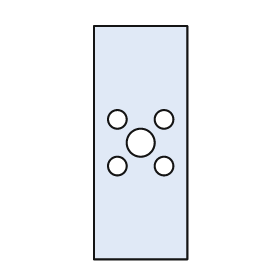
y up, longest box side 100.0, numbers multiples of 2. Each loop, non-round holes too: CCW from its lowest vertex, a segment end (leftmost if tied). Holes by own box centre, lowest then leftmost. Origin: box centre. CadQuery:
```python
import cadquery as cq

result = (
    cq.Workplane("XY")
    .moveTo(-20.0, -50.0)
    .lineTo(20.0, -50.0)
    .lineTo(20.0, 50.0)
    .lineTo(-20.0, 50.0)
    .close()
    .moveTo(-10.0, -10.0)
    .circle(4.0)
    .moveTo(10.0, -10.0)
    .circle(4.0)
    .moveTo(0.0, 0.0)
    .circle(6.0)
    .moveTo(-10.0, 10.0)
    .circle(4.0)
    .moveTo(10.0, 10.0)
    .circle(4.0)
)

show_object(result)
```